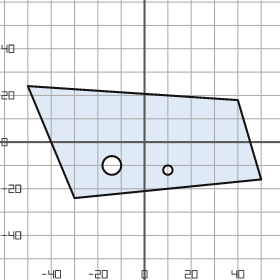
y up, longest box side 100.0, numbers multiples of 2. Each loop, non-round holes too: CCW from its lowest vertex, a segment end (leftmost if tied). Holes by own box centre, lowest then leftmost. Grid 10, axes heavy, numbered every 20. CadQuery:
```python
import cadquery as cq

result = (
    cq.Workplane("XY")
    .moveTo(-30.0, -24.0)
    .lineTo(50.0, -16.0)
    .lineTo(40.0, 18.0)
    .lineTo(-50.0, 24.0)
    .close()
    .moveTo(10.0, -12.0)
    .circle(2.0)
    .moveTo(-14.0, -10.0)
    .circle(4.0)
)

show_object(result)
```